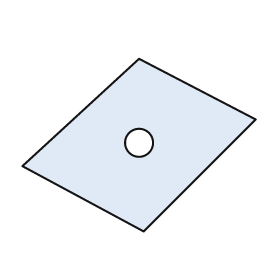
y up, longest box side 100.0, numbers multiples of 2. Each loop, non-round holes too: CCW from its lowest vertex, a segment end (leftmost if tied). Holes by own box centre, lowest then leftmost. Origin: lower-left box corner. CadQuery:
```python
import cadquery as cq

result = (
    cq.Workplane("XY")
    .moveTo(52.0, 0.0)
    .lineTo(100.0, 48.0)
    .lineTo(50.0, 74.0)
    .lineTo(0.0, 28.0)
    .close()
    .moveTo(50.0, 38.0)
    .circle(6.0)
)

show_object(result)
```